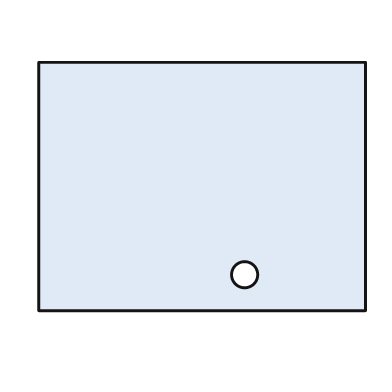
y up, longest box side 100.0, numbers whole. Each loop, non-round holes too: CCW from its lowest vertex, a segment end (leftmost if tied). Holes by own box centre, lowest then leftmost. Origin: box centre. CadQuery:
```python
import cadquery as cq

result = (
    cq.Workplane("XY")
    .moveTo(-50.0, -38.0)
    .lineTo(50.0, -38.0)
    .lineTo(50.0, 38.0)
    .lineTo(-50.0, 38.0)
    .close()
    .moveTo(13.0, -27.0)
    .circle(4.0)
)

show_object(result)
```